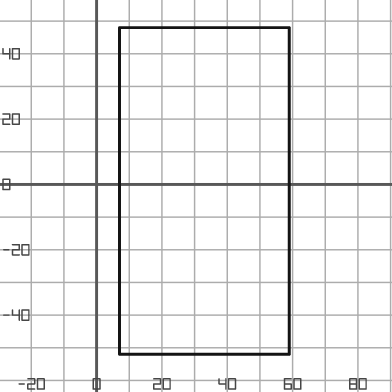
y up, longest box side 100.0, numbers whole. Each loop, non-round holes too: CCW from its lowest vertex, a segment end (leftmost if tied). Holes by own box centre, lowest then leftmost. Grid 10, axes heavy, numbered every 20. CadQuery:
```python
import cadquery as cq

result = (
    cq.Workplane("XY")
    .moveTo(7.0, -52.0)
    .lineTo(59.0, -52.0)
    .lineTo(59.0, 48.0)
    .lineTo(7.0, 48.0)
    .close()
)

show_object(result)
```